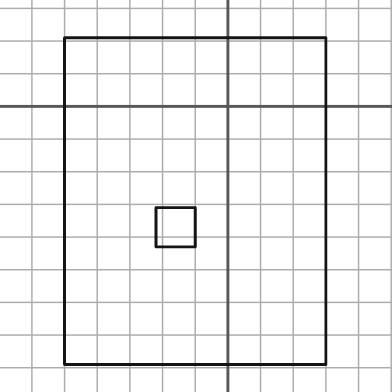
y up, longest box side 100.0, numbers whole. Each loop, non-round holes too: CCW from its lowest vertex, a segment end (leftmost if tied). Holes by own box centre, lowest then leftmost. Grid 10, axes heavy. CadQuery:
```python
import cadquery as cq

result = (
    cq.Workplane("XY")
    .moveTo(-50.0, -79.0)
    .lineTo(30.0, -79.0)
    .lineTo(30.0, 21.0)
    .lineTo(-50.0, 21.0)
    .close()
    .moveTo(-22.0, -43.0)
    .lineTo(-10.0, -43.0)
    .lineTo(-10.0, -31.0)
    .lineTo(-22.0, -31.0)
    .close()
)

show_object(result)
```